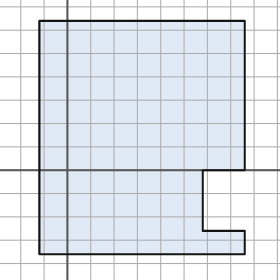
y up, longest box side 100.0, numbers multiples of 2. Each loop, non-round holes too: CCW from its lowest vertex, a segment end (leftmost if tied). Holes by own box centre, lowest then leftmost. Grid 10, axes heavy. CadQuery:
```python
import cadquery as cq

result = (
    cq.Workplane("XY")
    .moveTo(-12.0, -36.0)
    .lineTo(76.0, -36.0)
    .lineTo(76.0, -26.0)
    .lineTo(58.0, -26.0)
    .lineTo(58.0, 0.0)
    .lineTo(76.0, 0.0)
    .lineTo(76.0, 64.0)
    .lineTo(-12.0, 64.0)
    .close()
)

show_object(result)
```